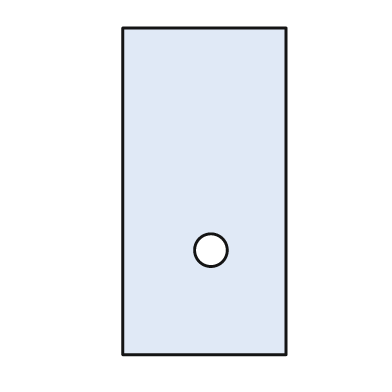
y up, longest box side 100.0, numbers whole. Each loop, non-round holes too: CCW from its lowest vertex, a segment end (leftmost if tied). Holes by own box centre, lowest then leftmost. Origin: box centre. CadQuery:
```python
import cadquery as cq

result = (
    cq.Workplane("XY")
    .moveTo(-25.0, -50.0)
    .lineTo(25.0, -50.0)
    .lineTo(25.0, 50.0)
    .lineTo(-25.0, 50.0)
    .close()
    .moveTo(2.0, -18.0)
    .circle(5.0)
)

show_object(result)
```